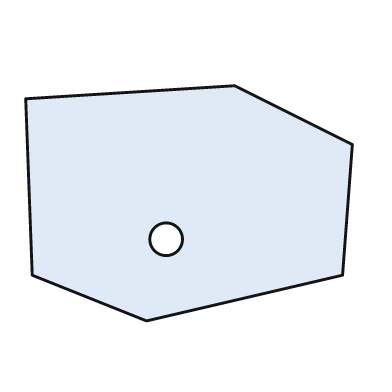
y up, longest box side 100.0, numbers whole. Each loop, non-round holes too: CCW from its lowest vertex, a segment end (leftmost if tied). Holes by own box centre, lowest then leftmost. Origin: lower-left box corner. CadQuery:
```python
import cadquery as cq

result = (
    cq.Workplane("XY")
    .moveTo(37.0, 0.0)
    .lineTo(97.0, 14.0)
    .lineTo(100.0, 54.0)
    .lineTo(64.0, 72.0)
    .lineTo(0.0, 68.0)
    .lineTo(2.0, 14.0)
    .close()
    .moveTo(43.0, 25.0)
    .circle(5.0)
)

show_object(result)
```